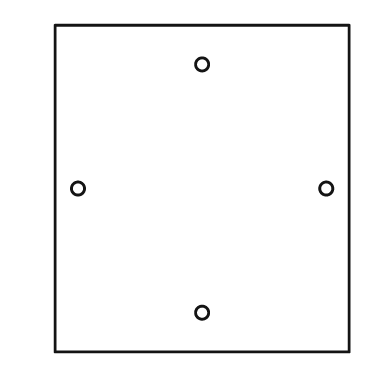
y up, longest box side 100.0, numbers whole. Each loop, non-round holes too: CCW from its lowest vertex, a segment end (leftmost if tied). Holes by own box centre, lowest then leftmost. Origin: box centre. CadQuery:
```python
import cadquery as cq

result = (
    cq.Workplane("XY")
    .moveTo(-45.0, -50.0)
    .lineTo(45.0, -50.0)
    .lineTo(45.0, 50.0)
    .lineTo(-45.0, 50.0)
    .close()
    .moveTo(0.0, -38.0)
    .circle(2.0)
    .moveTo(-38.0, 0.0)
    .circle(2.0)
    .moveTo(38.0, 0.0)
    .circle(2.0)
    .moveTo(0.0, 38.0)
    .circle(2.0)
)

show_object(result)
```